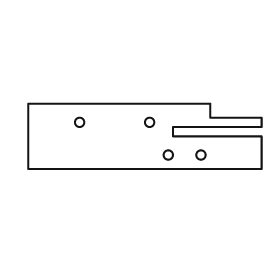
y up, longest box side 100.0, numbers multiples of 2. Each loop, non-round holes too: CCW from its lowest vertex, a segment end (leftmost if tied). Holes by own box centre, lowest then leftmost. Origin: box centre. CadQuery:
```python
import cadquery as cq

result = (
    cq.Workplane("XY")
    .moveTo(-50.0, -14.0)
    .lineTo(50.0, -14.0)
    .lineTo(50.0, 0.0)
    .lineTo(12.0, 0.0)
    .lineTo(12.0, 4.0)
    .lineTo(50.0, 4.0)
    .lineTo(50.0, 8.0)
    .lineTo(28.0, 8.0)
    .lineTo(28.0, 14.0)
    .lineTo(-50.0, 14.0)
    .close()
    .moveTo(10.0, -8.0)
    .circle(2.0)
    .moveTo(24.0, -8.0)
    .circle(2.0)
    .moveTo(-28.0, 6.0)
    .circle(2.0)
    .moveTo(2.0, 6.0)
    .circle(2.0)
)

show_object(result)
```